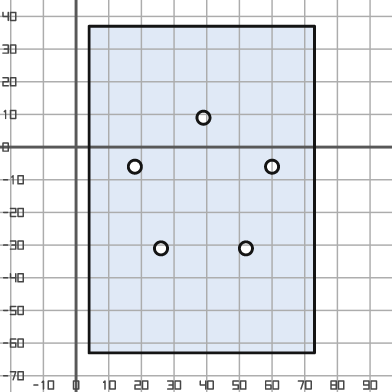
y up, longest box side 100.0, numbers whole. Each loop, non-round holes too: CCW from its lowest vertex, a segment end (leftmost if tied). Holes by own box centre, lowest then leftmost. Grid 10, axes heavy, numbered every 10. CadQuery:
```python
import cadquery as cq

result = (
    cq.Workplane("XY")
    .moveTo(4.0, -63.0)
    .lineTo(73.0, -63.0)
    .lineTo(73.0, 37.0)
    .lineTo(4.0, 37.0)
    .close()
    .moveTo(26.0, -31.0)
    .circle(2.0)
    .moveTo(52.0, -31.0)
    .circle(2.0)
    .moveTo(18.0, -6.0)
    .circle(2.0)
    .moveTo(60.0, -6.0)
    .circle(2.0)
    .moveTo(39.0, 9.0)
    .circle(2.0)
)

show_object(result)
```